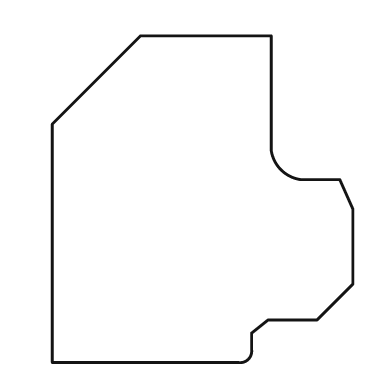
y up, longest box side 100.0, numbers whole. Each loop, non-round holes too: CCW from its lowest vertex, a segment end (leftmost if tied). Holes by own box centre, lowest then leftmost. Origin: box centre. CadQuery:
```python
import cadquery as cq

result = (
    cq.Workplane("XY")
    .moveTo(-46.0, -50.0)
    .lineTo(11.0, -50.0)
    .threePointArc((14.0, -49.0), (15.0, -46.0))
    .lineTo(15.0, -41.0)
    .lineTo(20.0, -37.0)
    .lineTo(35.0, -37.0)
    .lineTo(46.0, -26.0)
    .lineTo(46.0, -3.0)
    .lineTo(42.0, 6.0)
    .lineTo(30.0, 6.0)
    .threePointArc((24.0, 9.0), (21.0, 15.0))
    .lineTo(21.0, 50.0)
    .lineTo(-19.0, 50.0)
    .lineTo(-46.0, 23.0)
    .close()
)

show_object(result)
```